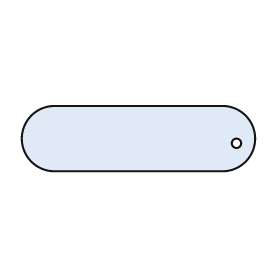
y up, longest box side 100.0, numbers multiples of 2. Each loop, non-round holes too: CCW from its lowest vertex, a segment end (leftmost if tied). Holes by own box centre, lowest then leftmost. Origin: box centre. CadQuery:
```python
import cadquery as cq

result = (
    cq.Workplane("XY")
    .moveTo(-36.0, -14.0)
    .lineTo(36.0, -14.0)
    .threePointArc((50.0, 0.0), (36.0, 14.0))
    .lineTo(-36.0, 14.0)
    .threePointArc((-50.0, 0.0), (-36.0, -14.0))
    .close()
    .moveTo(42.0, -2.0)
    .circle(2.0)
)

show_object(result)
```